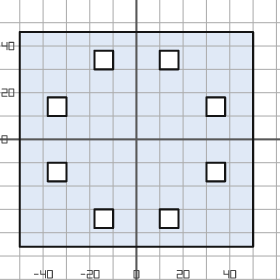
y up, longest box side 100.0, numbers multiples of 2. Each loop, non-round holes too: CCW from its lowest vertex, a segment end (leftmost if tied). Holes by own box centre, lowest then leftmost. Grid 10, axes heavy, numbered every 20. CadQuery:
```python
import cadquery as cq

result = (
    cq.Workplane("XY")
    .moveTo(-50.0, -46.0)
    .lineTo(50.0, -46.0)
    .lineTo(50.0, 46.0)
    .lineTo(-50.0, 46.0)
    .close()
    .moveTo(-18.0, -38.0)
    .lineTo(-10.0, -38.0)
    .lineTo(-10.0, -30.0)
    .lineTo(-18.0, -30.0)
    .close()
    .moveTo(10.0, -38.0)
    .lineTo(18.0, -38.0)
    .lineTo(18.0, -30.0)
    .lineTo(10.0, -30.0)
    .close()
    .moveTo(-38.0, -18.0)
    .lineTo(-30.0, -18.0)
    .lineTo(-30.0, -10.0)
    .lineTo(-38.0, -10.0)
    .close()
    .moveTo(30.0, -18.0)
    .lineTo(38.0, -18.0)
    .lineTo(38.0, -10.0)
    .lineTo(30.0, -10.0)
    .close()
    .moveTo(-38.0, 10.0)
    .lineTo(-30.0, 10.0)
    .lineTo(-30.0, 18.0)
    .lineTo(-38.0, 18.0)
    .close()
    .moveTo(30.0, 10.0)
    .lineTo(38.0, 10.0)
    .lineTo(38.0, 18.0)
    .lineTo(30.0, 18.0)
    .close()
    .moveTo(-18.0, 30.0)
    .lineTo(-10.0, 30.0)
    .lineTo(-10.0, 38.0)
    .lineTo(-18.0, 38.0)
    .close()
    .moveTo(10.0, 30.0)
    .lineTo(18.0, 30.0)
    .lineTo(18.0, 38.0)
    .lineTo(10.0, 38.0)
    .close()
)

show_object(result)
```